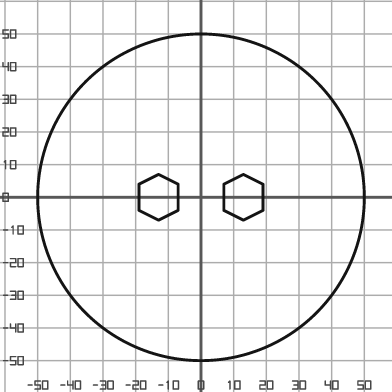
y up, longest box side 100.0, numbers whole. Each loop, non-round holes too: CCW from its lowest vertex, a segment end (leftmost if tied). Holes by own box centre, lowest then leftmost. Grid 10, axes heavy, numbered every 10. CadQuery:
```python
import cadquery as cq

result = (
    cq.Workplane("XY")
    .moveTo(0.0, 0.0)
    .circle(50.0)
    .moveTo(-13.0, -7.0)
    .lineTo(-7.0, -4.0)
    .lineTo(-7.0, 4.0)
    .lineTo(-13.0, 7.0)
    .lineTo(-19.0, 4.0)
    .lineTo(-19.0, -4.0)
    .close()
    .moveTo(13.0, -7.0)
    .lineTo(19.0, -4.0)
    .lineTo(19.0, 4.0)
    .lineTo(13.0, 7.0)
    .lineTo(7.0, 4.0)
    .lineTo(7.0, -4.0)
    .close()
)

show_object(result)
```